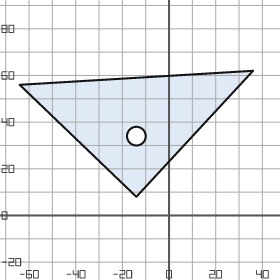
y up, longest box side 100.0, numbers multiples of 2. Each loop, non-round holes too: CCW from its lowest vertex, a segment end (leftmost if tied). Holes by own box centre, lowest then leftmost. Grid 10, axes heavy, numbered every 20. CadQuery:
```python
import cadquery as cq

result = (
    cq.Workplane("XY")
    .moveTo(-14.0, 8.0)
    .lineTo(36.0, 62.0)
    .lineTo(-64.0, 56.0)
    .close()
    .moveTo(-14.0, 34.0)
    .circle(4.0)
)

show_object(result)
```